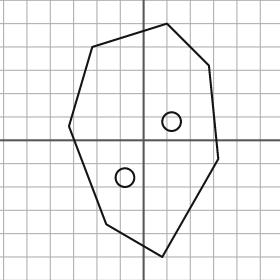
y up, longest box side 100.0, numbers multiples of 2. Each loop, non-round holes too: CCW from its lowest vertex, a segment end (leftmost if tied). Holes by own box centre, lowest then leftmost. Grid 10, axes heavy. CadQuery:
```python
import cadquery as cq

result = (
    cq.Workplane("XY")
    .moveTo(8.0, -50.0)
    .lineTo(32.0, -8.0)
    .lineTo(28.0, 32.0)
    .lineTo(10.0, 50.0)
    .lineTo(-22.0, 40.0)
    .lineTo(-32.0, 6.0)
    .lineTo(-16.0, -36.0)
    .close()
    .moveTo(-8.0, -16.0)
    .circle(4.0)
    .moveTo(12.0, 8.0)
    .circle(4.0)
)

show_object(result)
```